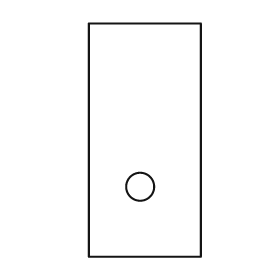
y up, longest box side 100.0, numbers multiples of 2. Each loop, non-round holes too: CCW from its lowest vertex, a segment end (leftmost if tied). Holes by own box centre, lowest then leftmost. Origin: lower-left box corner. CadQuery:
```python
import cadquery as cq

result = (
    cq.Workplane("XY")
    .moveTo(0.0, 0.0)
    .lineTo(48.0, 0.0)
    .lineTo(48.0, 100.0)
    .lineTo(0.0, 100.0)
    .close()
    .moveTo(22.0, 30.0)
    .circle(6.0)
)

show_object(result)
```